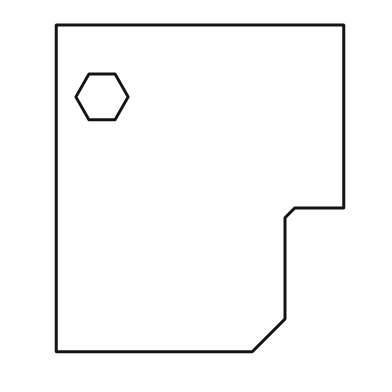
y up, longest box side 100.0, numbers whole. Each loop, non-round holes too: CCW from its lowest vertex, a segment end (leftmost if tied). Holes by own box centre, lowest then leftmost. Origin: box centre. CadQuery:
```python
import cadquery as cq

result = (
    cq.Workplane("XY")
    .moveTo(-44.0, -50.0)
    .lineTo(16.0, -50.0)
    .lineTo(26.0, -40.0)
    .lineTo(26.0, -9.0)
    .lineTo(29.0, -6.0)
    .lineTo(44.0, -6.0)
    .lineTo(44.0, 50.0)
    .lineTo(-44.0, 50.0)
    .close()
    .moveTo(-34.0, 21.0)
    .lineTo(-26.0, 21.0)
    .lineTo(-22.0, 28.0)
    .lineTo(-26.0, 35.0)
    .lineTo(-34.0, 35.0)
    .lineTo(-38.0, 28.0)
    .close()
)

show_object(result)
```